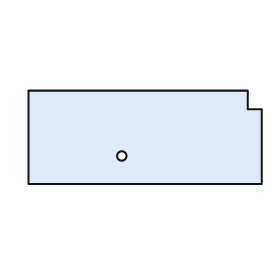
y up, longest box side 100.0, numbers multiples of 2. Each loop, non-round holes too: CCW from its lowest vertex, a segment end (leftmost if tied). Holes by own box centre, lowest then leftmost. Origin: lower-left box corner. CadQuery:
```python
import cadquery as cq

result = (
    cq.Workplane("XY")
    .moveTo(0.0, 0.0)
    .lineTo(100.0, 0.0)
    .lineTo(100.0, 32.0)
    .lineTo(94.0, 32.0)
    .lineTo(94.0, 40.0)
    .lineTo(0.0, 40.0)
    .close()
    .moveTo(40.0, 12.0)
    .circle(2.0)
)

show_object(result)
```